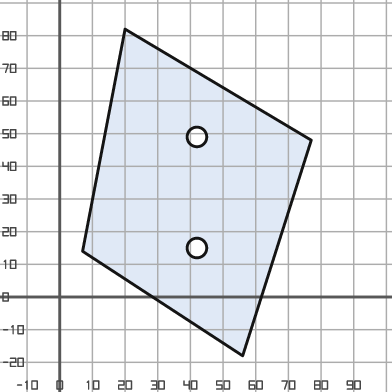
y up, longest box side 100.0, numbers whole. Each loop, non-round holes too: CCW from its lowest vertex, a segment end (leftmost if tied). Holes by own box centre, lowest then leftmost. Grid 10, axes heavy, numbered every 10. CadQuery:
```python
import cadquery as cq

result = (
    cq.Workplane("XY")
    .moveTo(56.0, -18.0)
    .lineTo(77.0, 48.0)
    .lineTo(20.0, 82.0)
    .lineTo(7.0, 14.0)
    .close()
    .moveTo(42.0, 15.0)
    .circle(3.0)
    .moveTo(42.0, 49.0)
    .circle(3.0)
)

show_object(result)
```